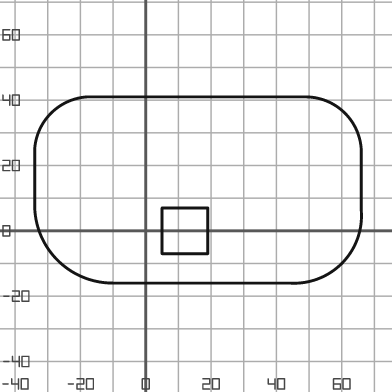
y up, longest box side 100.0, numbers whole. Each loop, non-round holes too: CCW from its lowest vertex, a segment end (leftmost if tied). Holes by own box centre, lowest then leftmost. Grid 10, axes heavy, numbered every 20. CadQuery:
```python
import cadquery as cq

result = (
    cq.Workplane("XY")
    .moveTo(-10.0, -16.0)
    .lineTo(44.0, -16.0)
    .threePointArc((60.0, -10.0), (66.0, 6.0))
    .lineTo(66.0, 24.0)
    .threePointArc((61.0, 36.0), (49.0, 41.0))
    .lineTo(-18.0, 41.0)
    .threePointArc((-29.0, 36.0), (-34.0, 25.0))
    .lineTo(-34.0, 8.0)
    .threePointArc((-27.0, -9.0), (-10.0, -16.0))
    .close()
    .moveTo(5.0, -7.0)
    .lineTo(19.0, -7.0)
    .lineTo(19.0, 7.0)
    .lineTo(5.0, 7.0)
    .close()
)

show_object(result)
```